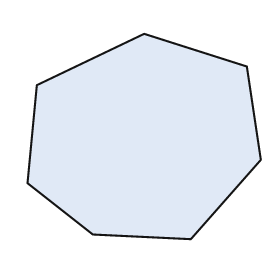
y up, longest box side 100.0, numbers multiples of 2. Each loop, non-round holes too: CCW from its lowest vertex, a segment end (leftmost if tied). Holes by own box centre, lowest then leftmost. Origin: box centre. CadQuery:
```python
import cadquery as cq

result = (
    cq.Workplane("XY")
    .moveTo(20.0, -44.0)
    .lineTo(50.0, -10.0)
    .lineTo(44.0, 30.0)
    .lineTo(0.0, 44.0)
    .lineTo(-46.0, 22.0)
    .lineTo(-50.0, -20.0)
    .lineTo(-22.0, -42.0)
    .close()
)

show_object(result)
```